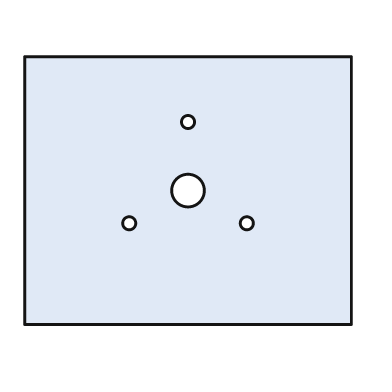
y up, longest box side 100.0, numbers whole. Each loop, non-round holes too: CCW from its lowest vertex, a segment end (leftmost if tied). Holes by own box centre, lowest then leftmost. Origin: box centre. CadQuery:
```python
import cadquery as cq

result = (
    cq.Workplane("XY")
    .moveTo(-50.0, -41.0)
    .lineTo(50.0, -41.0)
    .lineTo(50.0, 41.0)
    .lineTo(-50.0, 41.0)
    .close()
    .moveTo(-18.0, -10.0)
    .circle(2.0)
    .moveTo(18.0, -10.0)
    .circle(2.0)
    .moveTo(0.0, 0.0)
    .circle(5.0)
    .moveTo(0.0, 21.0)
    .circle(2.0)
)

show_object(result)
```